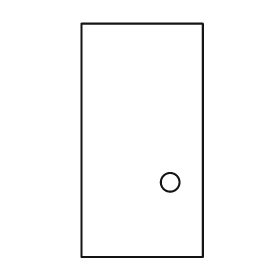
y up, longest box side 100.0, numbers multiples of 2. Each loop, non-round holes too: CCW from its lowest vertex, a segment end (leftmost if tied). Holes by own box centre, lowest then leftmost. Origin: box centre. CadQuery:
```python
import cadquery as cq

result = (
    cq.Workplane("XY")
    .moveTo(-26.0, -50.0)
    .lineTo(26.0, -50.0)
    .lineTo(26.0, 50.0)
    .lineTo(-26.0, 50.0)
    .close()
    .moveTo(12.0, -18.0)
    .circle(4.0)
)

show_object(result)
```